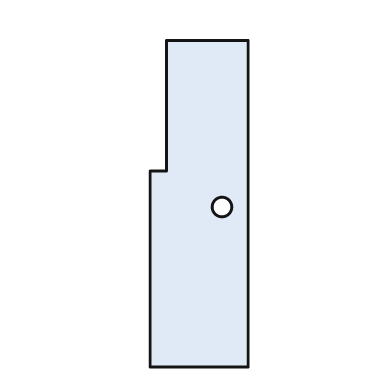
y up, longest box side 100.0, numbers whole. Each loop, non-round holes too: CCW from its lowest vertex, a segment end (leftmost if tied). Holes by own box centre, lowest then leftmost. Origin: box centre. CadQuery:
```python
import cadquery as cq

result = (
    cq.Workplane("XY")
    .moveTo(-15.0, -50.0)
    .lineTo(15.0, -50.0)
    .lineTo(15.0, 50.0)
    .lineTo(-10.0, 50.0)
    .lineTo(-10.0, 10.0)
    .lineTo(-15.0, 10.0)
    .close()
    .moveTo(7.0, -1.0)
    .circle(3.0)
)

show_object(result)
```